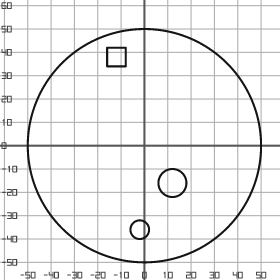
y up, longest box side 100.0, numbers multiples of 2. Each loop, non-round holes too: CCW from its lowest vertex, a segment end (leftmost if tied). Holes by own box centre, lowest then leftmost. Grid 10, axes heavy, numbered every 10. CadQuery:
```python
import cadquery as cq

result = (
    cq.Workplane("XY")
    .moveTo(0.0, 0.0)
    .circle(50.0)
    .moveTo(-2.0, -36.0)
    .circle(4.0)
    .moveTo(12.0, -16.0)
    .circle(6.0)
    .moveTo(-16.0, 34.0)
    .lineTo(-8.0, 34.0)
    .lineTo(-8.0, 42.0)
    .lineTo(-16.0, 42.0)
    .close()
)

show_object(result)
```